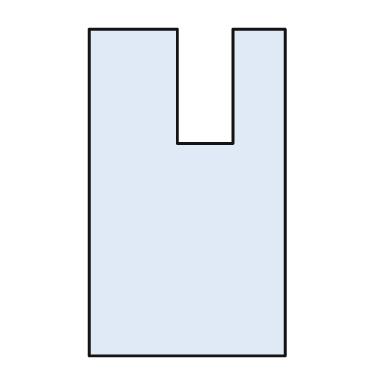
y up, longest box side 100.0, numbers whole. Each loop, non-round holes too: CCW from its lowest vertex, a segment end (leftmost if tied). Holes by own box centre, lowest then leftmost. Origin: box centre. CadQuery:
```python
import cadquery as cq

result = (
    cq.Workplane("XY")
    .moveTo(-30.0, -50.0)
    .lineTo(30.0, -50.0)
    .lineTo(30.0, 50.0)
    .lineTo(14.0, 50.0)
    .lineTo(14.0, 15.0)
    .lineTo(-3.0, 15.0)
    .lineTo(-3.0, 50.0)
    .lineTo(-30.0, 50.0)
    .close()
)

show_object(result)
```